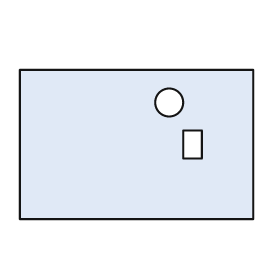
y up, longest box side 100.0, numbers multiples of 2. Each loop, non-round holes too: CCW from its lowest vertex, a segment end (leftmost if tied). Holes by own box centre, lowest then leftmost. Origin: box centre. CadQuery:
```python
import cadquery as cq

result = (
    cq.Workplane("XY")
    .moveTo(-50.0, -32.0)
    .lineTo(50.0, -32.0)
    .lineTo(50.0, 32.0)
    .lineTo(-50.0, 32.0)
    .close()
    .moveTo(20.0, -6.0)
    .lineTo(28.0, -6.0)
    .lineTo(28.0, 6.0)
    .lineTo(20.0, 6.0)
    .close()
    .moveTo(14.0, 18.0)
    .circle(6.0)
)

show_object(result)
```